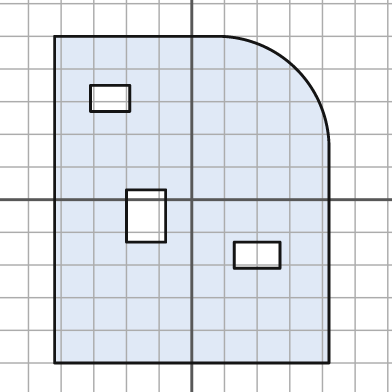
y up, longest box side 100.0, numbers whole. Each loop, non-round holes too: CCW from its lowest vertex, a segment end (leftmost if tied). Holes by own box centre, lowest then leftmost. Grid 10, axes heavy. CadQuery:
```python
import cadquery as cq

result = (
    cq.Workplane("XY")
    .moveTo(-42.0, -50.0)
    .lineTo(42.0, -50.0)
    .lineTo(42.0, 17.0)
    .threePointArc((32.0, 40.0), (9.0, 50.0))
    .lineTo(-42.0, 50.0)
    .close()
    .moveTo(13.0, -21.0)
    .lineTo(27.0, -21.0)
    .lineTo(27.0, -13.0)
    .lineTo(13.0, -13.0)
    .close()
    .moveTo(-20.0, -13.0)
    .lineTo(-8.0, -13.0)
    .lineTo(-8.0, 3.0)
    .lineTo(-20.0, 3.0)
    .close()
    .moveTo(-31.0, 27.0)
    .lineTo(-19.0, 27.0)
    .lineTo(-19.0, 35.0)
    .lineTo(-31.0, 35.0)
    .close()
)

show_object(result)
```